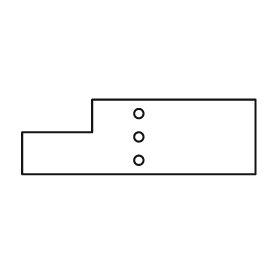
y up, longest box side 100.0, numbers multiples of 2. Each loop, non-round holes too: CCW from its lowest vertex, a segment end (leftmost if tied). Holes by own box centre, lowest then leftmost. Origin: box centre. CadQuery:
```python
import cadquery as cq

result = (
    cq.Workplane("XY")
    .moveTo(-50.0, -16.0)
    .lineTo(50.0, -16.0)
    .lineTo(50.0, 16.0)
    .lineTo(-20.0, 16.0)
    .lineTo(-20.0, 2.0)
    .lineTo(-50.0, 2.0)
    .close()
    .moveTo(0.0, -10.0)
    .circle(2.0)
    .moveTo(0.0, 0.0)
    .circle(2.0)
    .moveTo(0.0, 10.0)
    .circle(2.0)
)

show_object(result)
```